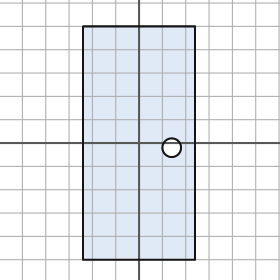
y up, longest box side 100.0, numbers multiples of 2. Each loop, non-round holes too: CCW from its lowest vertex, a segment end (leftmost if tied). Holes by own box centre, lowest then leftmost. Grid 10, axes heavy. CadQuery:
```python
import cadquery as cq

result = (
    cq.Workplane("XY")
    .moveTo(-24.0, -50.0)
    .lineTo(24.0, -50.0)
    .lineTo(24.0, 50.0)
    .lineTo(-24.0, 50.0)
    .close()
    .moveTo(14.0, -2.0)
    .circle(4.0)
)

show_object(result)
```